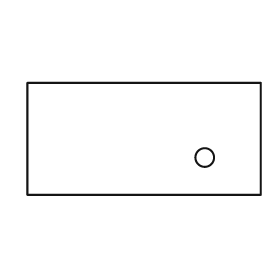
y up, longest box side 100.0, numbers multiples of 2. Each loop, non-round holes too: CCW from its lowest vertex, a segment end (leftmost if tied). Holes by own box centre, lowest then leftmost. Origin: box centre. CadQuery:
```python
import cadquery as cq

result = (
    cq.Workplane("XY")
    .moveTo(-50.0, -24.0)
    .lineTo(50.0, -24.0)
    .lineTo(50.0, 24.0)
    .lineTo(-50.0, 24.0)
    .close()
    .moveTo(26.0, -8.0)
    .circle(4.0)
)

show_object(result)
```